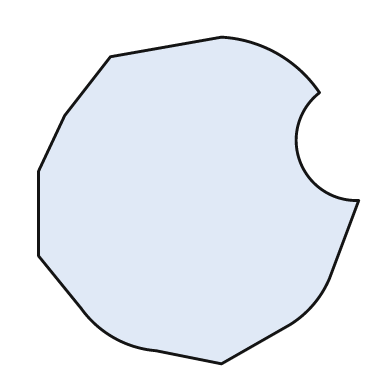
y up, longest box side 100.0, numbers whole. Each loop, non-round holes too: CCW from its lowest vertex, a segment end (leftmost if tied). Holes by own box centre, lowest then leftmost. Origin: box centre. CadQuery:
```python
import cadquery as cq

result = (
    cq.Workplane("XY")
    .moveTo(7.0, -50.0)
    .lineTo(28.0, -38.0)
    .threePointArc((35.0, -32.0), (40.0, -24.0))
    .lineTo(49.0, 0.0)
    .threePointArc((31.0, 12.0), (37.0, 33.0))
    .threePointArc((24.0, 45.0), (7.0, 50.0))
    .lineTo(-27.0, 44.0)
    .lineTo(-41.0, 26.0)
    .lineTo(-49.0, 9.0)
    .lineTo(-49.0, -17.0)
    .lineTo(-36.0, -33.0)
    .threePointArc((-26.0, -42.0), (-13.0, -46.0))
    .close()
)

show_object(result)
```